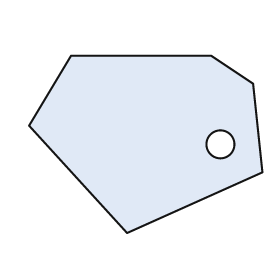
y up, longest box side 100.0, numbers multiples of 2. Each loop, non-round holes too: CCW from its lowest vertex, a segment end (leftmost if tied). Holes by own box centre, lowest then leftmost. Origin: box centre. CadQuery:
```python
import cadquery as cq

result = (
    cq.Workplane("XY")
    .moveTo(-8.0, -38.0)
    .lineTo(50.0, -12.0)
    .lineTo(46.0, 26.0)
    .lineTo(28.0, 38.0)
    .lineTo(-32.0, 38.0)
    .lineTo(-50.0, 8.0)
    .close()
    .moveTo(32.0, 0.0)
    .circle(6.0)
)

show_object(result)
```